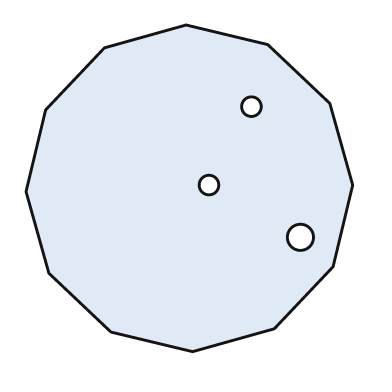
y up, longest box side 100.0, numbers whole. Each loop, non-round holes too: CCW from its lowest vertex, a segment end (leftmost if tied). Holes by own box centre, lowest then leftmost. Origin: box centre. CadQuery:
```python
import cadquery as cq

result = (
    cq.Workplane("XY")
    .moveTo(1.0, -50.0)
    .lineTo(26.0, -43.0)
    .lineTo(44.0, -24.0)
    .lineTo(50.0, 1.0)
    .lineTo(43.0, 26.0)
    .lineTo(24.0, 44.0)
    .lineTo(-1.0, 50.0)
    .lineTo(-26.0, 43.0)
    .lineTo(-44.0, 24.0)
    .lineTo(-50.0, -1.0)
    .lineTo(-43.0, -26.0)
    .lineTo(-24.0, -44.0)
    .close()
    .moveTo(34.0, -15.0)
    .circle(4.0)
    .moveTo(6.0, 1.0)
    .circle(3.0)
    .moveTo(19.0, 25.0)
    .circle(3.0)
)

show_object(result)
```